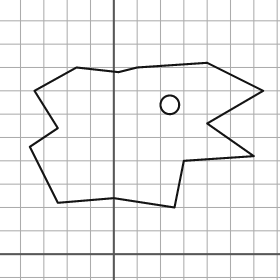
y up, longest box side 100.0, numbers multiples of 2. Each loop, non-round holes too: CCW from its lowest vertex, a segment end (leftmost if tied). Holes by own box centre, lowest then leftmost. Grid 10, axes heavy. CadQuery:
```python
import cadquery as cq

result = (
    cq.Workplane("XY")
    .moveTo(26.0, 20.0)
    .lineTo(30.0, 40.0)
    .lineTo(60.0, 42.0)
    .lineTo(40.0, 56.0)
    .lineTo(64.0, 70.0)
    .lineTo(40.0, 82.0)
    .lineTo(10.0, 80.0)
    .lineTo(2.0, 78.0)
    .lineTo(-16.0, 80.0)
    .lineTo(-34.0, 70.0)
    .lineTo(-24.0, 54.0)
    .lineTo(-36.0, 46.0)
    .lineTo(-24.0, 22.0)
    .lineTo(0.0, 24.0)
    .close()
    .moveTo(24.0, 64.0)
    .circle(4.0)
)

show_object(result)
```